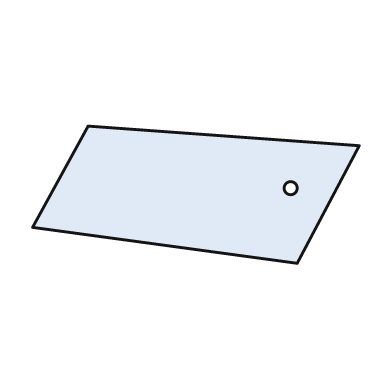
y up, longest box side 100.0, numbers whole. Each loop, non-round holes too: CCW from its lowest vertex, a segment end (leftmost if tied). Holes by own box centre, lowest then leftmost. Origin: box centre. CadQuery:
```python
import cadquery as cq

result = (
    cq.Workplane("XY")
    .moveTo(31.0, -21.0)
    .lineTo(50.0, 15.0)
    .lineTo(-33.0, 21.0)
    .lineTo(-50.0, -10.0)
    .close()
    .moveTo(29.0, 2.0)
    .circle(2.0)
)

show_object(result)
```